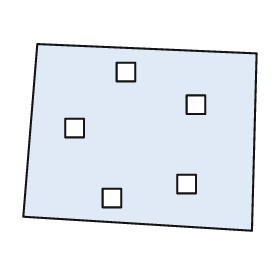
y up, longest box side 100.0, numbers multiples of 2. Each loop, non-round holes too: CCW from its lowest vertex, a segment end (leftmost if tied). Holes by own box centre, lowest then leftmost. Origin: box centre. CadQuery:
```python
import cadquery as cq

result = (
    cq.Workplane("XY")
    .moveTo(48.0, -40.0)
    .lineTo(50.0, 36.0)
    .lineTo(-44.0, 40.0)
    .lineTo(-50.0, -34.0)
    .close()
    .moveTo(-16.0, -30.0)
    .lineTo(-8.0, -30.0)
    .lineTo(-8.0, -22.0)
    .lineTo(-16.0, -22.0)
    .close()
    .moveTo(16.0, -24.0)
    .lineTo(24.0, -24.0)
    .lineTo(24.0, -16.0)
    .lineTo(16.0, -16.0)
    .close()
    .moveTo(-32.0, 0.0)
    .lineTo(-24.0, 0.0)
    .lineTo(-24.0, 8.0)
    .lineTo(-32.0, 8.0)
    .close()
    .moveTo(20.0, 10.0)
    .lineTo(28.0, 10.0)
    .lineTo(28.0, 18.0)
    .lineTo(20.0, 18.0)
    .close()
    .moveTo(-10.0, 24.0)
    .lineTo(-2.0, 24.0)
    .lineTo(-2.0, 32.0)
    .lineTo(-10.0, 32.0)
    .close()
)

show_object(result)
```